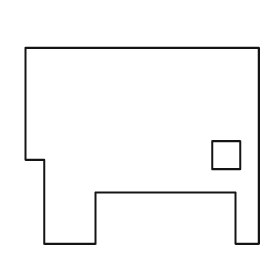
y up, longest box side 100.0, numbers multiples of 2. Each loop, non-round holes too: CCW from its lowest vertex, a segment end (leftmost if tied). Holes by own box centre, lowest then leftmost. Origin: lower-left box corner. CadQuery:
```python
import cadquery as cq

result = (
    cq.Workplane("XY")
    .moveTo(8.0, 0.0)
    .lineTo(30.0, 0.0)
    .lineTo(30.0, 22.0)
    .lineTo(90.0, 22.0)
    .lineTo(90.0, 0.0)
    .lineTo(100.0, 0.0)
    .lineTo(100.0, 84.0)
    .lineTo(0.0, 84.0)
    .lineTo(0.0, 36.0)
    .lineTo(8.0, 36.0)
    .close()
    .moveTo(80.0, 32.0)
    .lineTo(92.0, 32.0)
    .lineTo(92.0, 44.0)
    .lineTo(80.0, 44.0)
    .close()
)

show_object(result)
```